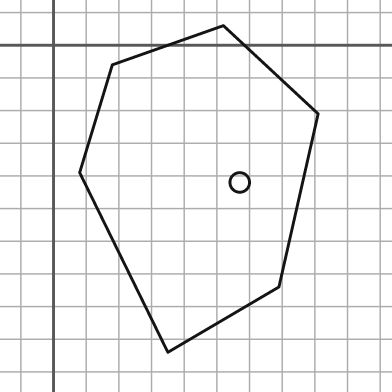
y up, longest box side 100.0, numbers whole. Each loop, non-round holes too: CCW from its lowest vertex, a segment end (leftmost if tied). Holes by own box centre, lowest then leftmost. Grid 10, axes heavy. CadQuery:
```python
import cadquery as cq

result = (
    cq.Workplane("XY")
    .moveTo(35.0, -94.0)
    .lineTo(69.0, -74.0)
    .lineTo(81.0, -21.0)
    .lineTo(52.0, 6.0)
    .lineTo(18.0, -6.0)
    .lineTo(8.0, -39.0)
    .close()
    .moveTo(57.0, -42.0)
    .circle(3.0)
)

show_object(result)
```